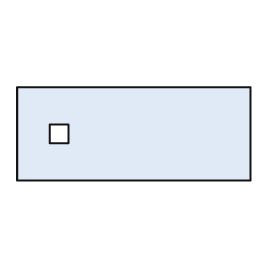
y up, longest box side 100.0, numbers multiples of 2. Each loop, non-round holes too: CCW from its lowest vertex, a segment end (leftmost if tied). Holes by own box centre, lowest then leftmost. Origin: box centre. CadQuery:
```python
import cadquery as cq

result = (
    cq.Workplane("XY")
    .moveTo(-50.0, -20.0)
    .lineTo(50.0, -20.0)
    .lineTo(50.0, 20.0)
    .lineTo(-50.0, 20.0)
    .close()
    .moveTo(-36.0, -4.0)
    .lineTo(-28.0, -4.0)
    .lineTo(-28.0, 4.0)
    .lineTo(-36.0, 4.0)
    .close()
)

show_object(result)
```